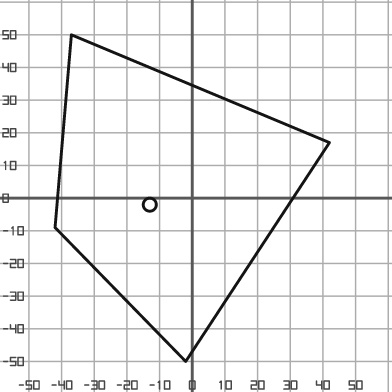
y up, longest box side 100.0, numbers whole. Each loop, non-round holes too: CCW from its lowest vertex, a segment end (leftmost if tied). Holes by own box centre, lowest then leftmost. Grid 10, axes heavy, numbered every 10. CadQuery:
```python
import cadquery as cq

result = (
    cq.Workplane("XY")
    .moveTo(-2.0, -50.0)
    .lineTo(42.0, 17.0)
    .lineTo(-37.0, 50.0)
    .lineTo(-42.0, -9.0)
    .close()
    .moveTo(-13.0, -2.0)
    .circle(2.0)
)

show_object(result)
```